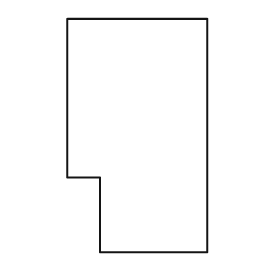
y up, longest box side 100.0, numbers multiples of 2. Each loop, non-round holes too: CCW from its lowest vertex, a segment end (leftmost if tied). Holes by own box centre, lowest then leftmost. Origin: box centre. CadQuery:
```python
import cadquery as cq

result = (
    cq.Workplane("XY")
    .moveTo(-16.0, -50.0)
    .lineTo(30.0, -50.0)
    .lineTo(30.0, 50.0)
    .lineTo(-30.0, 50.0)
    .lineTo(-30.0, -18.0)
    .lineTo(-16.0, -18.0)
    .close()
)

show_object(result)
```